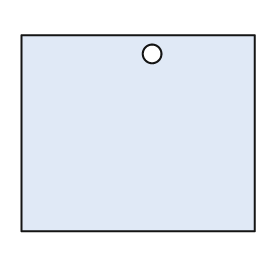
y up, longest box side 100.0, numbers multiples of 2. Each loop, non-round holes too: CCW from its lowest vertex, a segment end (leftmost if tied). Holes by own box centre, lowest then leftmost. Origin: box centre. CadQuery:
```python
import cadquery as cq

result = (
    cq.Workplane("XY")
    .moveTo(-50.0, -42.0)
    .lineTo(50.0, -42.0)
    .lineTo(50.0, 42.0)
    .lineTo(-50.0, 42.0)
    .close()
    .moveTo(6.0, 34.0)
    .circle(4.0)
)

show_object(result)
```